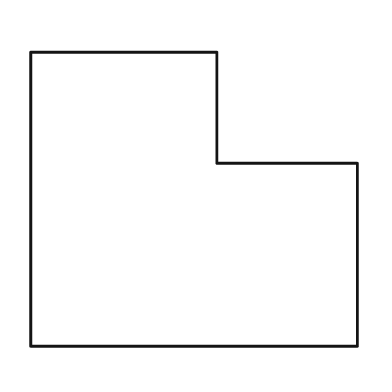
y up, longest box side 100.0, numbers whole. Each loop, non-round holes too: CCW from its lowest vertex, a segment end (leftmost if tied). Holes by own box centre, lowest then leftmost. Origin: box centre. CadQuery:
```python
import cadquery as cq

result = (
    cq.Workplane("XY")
    .moveTo(-50.0, -45.0)
    .lineTo(50.0, -45.0)
    .lineTo(50.0, 11.0)
    .lineTo(7.0, 11.0)
    .lineTo(7.0, 45.0)
    .lineTo(-50.0, 45.0)
    .close()
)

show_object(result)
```